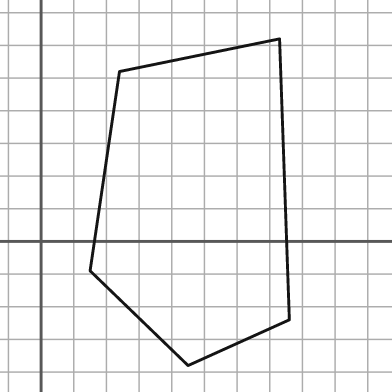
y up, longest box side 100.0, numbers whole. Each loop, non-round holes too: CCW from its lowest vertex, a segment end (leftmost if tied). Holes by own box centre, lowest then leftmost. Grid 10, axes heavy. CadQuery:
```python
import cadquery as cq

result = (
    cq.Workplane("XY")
    .moveTo(45.0, -38.0)
    .lineTo(76.0, -24.0)
    .lineTo(73.0, 62.0)
    .lineTo(24.0, 52.0)
    .lineTo(15.0, -9.0)
    .close()
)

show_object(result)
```